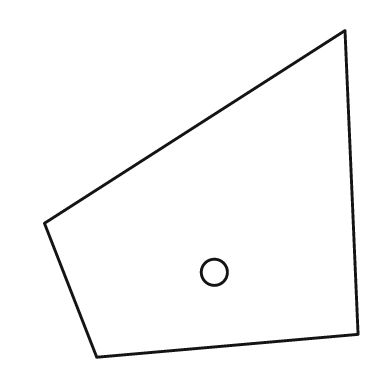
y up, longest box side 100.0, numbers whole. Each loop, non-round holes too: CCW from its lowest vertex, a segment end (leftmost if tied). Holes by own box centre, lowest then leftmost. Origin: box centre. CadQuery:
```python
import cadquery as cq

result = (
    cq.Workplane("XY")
    .moveTo(-32.0, -50.0)
    .lineTo(48.0, -43.0)
    .lineTo(44.0, 50.0)
    .lineTo(-48.0, -9.0)
    .close()
    .moveTo(4.0, -24.0)
    .circle(4.0)
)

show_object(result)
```